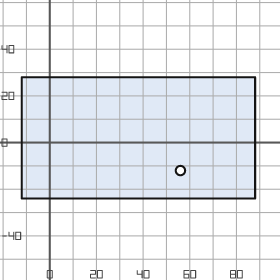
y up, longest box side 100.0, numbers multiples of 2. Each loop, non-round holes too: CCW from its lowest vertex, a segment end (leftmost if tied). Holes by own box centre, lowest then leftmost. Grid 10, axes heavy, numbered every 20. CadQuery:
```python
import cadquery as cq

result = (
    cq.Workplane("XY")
    .moveTo(-12.0, -24.0)
    .lineTo(88.0, -24.0)
    .lineTo(88.0, 28.0)
    .lineTo(-12.0, 28.0)
    .close()
    .moveTo(56.0, -12.0)
    .circle(2.0)
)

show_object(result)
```